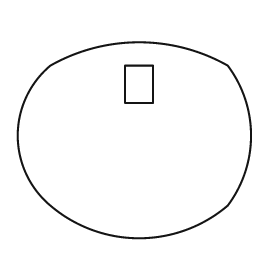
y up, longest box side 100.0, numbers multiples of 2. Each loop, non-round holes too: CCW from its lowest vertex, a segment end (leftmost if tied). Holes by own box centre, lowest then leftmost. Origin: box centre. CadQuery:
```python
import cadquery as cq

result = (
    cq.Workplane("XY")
    .moveTo(-36.0, -28.0)
    .threePointArc((2.0, -42.0), (40.0, -28.0))
    .threePointArc((50.0, 2.0), (40.0, 32.0))
    .threePointArc((2.0, 42.0), (-36.0, 32.0))
    .threePointArc((-50.0, 2.0), (-36.0, -28.0))
    .close()
    .moveTo(-4.0, 16.0)
    .lineTo(8.0, 16.0)
    .lineTo(8.0, 32.0)
    .lineTo(-4.0, 32.0)
    .close()
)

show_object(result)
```